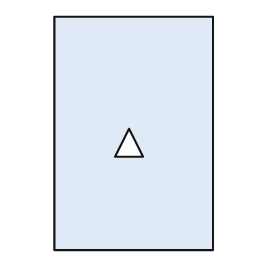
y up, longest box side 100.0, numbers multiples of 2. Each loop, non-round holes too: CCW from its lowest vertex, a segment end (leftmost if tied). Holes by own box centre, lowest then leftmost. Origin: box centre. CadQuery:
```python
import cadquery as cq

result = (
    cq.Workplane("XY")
    .moveTo(-34.0, -50.0)
    .lineTo(34.0, -50.0)
    .lineTo(34.0, 50.0)
    .lineTo(-34.0, 50.0)
    .close()
    .moveTo(-8.0, -10.0)
    .lineTo(4.0, -10.0)
    .lineTo(-2.0, 2.0)
    .close()
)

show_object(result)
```